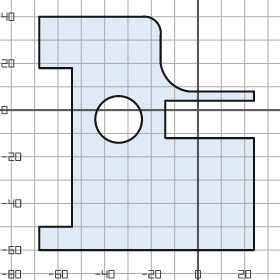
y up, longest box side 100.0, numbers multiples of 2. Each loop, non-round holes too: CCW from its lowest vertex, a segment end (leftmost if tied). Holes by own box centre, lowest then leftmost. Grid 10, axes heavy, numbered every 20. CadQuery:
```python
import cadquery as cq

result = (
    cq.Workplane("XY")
    .moveTo(-68.0, -60.0)
    .lineTo(24.0, -60.0)
    .lineTo(24.0, -12.0)
    .lineTo(-14.0, -12.0)
    .lineTo(-14.0, 4.0)
    .lineTo(24.0, 4.0)
    .lineTo(24.0, 8.0)
    .lineTo(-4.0, 8.0)
    .threePointArc((-12.0, 12.0), (-16.0, 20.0))
    .lineTo(-16.0, 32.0)
    .threePointArc((-18.0, 38.0), (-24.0, 40.0))
    .lineTo(-68.0, 40.0)
    .lineTo(-68.0, 18.0)
    .lineTo(-54.0, 18.0)
    .lineTo(-54.0, -50.0)
    .lineTo(-68.0, -50.0)
    .close()
    .moveTo(-34.0, -4.0)
    .circle(10.0)
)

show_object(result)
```